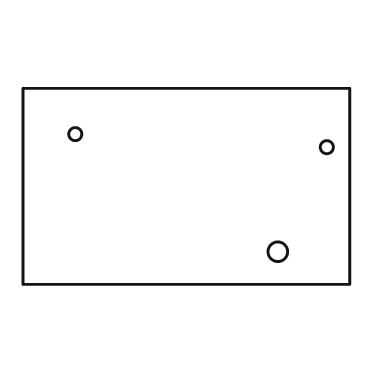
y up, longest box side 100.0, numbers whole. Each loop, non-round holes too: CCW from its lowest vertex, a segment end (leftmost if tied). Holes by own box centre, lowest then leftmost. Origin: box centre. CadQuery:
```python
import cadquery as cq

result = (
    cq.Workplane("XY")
    .moveTo(-50.0, -30.0)
    .lineTo(50.0, -30.0)
    .lineTo(50.0, 30.0)
    .lineTo(-50.0, 30.0)
    .close()
    .moveTo(28.0, -20.0)
    .circle(3.0)
    .moveTo(43.0, 12.0)
    .circle(2.0)
    .moveTo(-34.0, 16.0)
    .circle(2.0)
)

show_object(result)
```